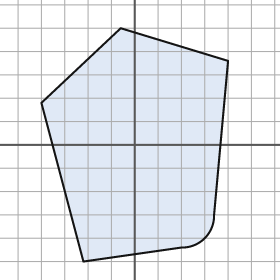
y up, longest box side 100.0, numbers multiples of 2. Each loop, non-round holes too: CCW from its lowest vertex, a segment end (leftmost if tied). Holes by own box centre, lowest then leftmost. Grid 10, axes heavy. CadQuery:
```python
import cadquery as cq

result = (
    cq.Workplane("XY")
    .moveTo(-22.0, -50.0)
    .lineTo(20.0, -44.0)
    .threePointArc((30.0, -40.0), (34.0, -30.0))
    .lineTo(40.0, 36.0)
    .lineTo(-6.0, 50.0)
    .lineTo(-40.0, 18.0)
    .close()
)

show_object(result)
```